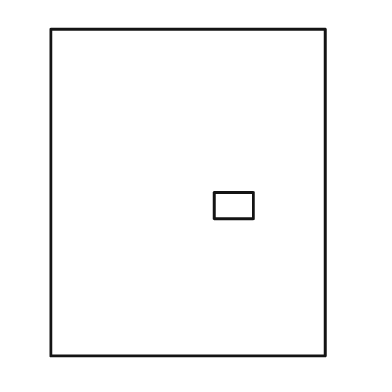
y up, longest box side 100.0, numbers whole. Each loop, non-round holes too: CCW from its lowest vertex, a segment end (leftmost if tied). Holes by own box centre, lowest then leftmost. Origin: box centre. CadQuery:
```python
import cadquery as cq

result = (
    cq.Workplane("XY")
    .moveTo(-42.0, -50.0)
    .lineTo(42.0, -50.0)
    .lineTo(42.0, 50.0)
    .lineTo(-42.0, 50.0)
    .close()
    .moveTo(8.0, -8.0)
    .lineTo(20.0, -8.0)
    .lineTo(20.0, 0.0)
    .lineTo(8.0, 0.0)
    .close()
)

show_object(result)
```